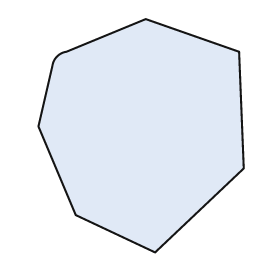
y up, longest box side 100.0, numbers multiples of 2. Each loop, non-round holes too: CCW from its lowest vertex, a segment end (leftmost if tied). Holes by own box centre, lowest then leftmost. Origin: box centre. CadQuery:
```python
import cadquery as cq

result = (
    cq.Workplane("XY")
    .moveTo(6.0, -50.0)
    .lineTo(44.0, -14.0)
    .lineTo(42.0, 36.0)
    .lineTo(2.0, 50.0)
    .lineTo(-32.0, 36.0)
    .threePointArc((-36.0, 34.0), (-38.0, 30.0))
    .lineTo(-44.0, 4.0)
    .lineTo(-28.0, -34.0)
    .close()
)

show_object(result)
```